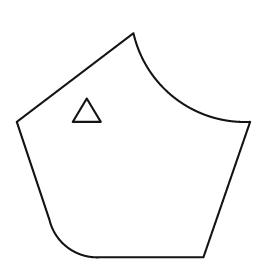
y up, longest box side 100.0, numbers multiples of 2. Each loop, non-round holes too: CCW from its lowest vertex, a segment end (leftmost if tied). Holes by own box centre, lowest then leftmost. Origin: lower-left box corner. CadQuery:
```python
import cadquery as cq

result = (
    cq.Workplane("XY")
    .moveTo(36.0, 0.0)
    .lineTo(80.0, 0.0)
    .lineTo(100.0, 58.0)
    .threePointArc((68.0, 68.0), (50.0, 96.0))
    .lineTo(0.0, 58.0)
    .lineTo(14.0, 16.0)
    .threePointArc((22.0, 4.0), (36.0, 0.0))
    .close()
    .moveTo(24.0, 58.0)
    .lineTo(36.0, 58.0)
    .lineTo(30.0, 68.0)
    .close()
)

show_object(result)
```